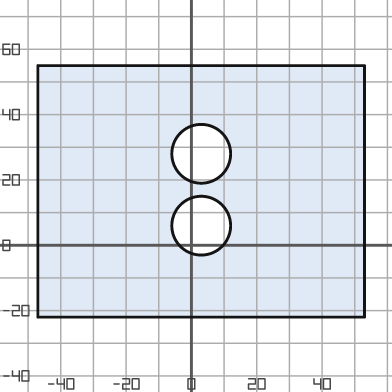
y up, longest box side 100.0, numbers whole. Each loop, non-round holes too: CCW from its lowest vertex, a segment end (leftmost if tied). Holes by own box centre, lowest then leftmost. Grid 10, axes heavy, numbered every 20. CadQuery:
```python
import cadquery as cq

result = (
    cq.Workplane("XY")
    .moveTo(-47.0, -22.0)
    .lineTo(53.0, -22.0)
    .lineTo(53.0, 55.0)
    .lineTo(-47.0, 55.0)
    .close()
    .moveTo(3.0, 6.0)
    .circle(9.0)
    .moveTo(3.0, 28.0)
    .circle(9.0)
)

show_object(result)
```